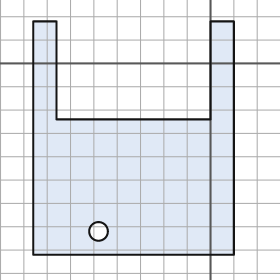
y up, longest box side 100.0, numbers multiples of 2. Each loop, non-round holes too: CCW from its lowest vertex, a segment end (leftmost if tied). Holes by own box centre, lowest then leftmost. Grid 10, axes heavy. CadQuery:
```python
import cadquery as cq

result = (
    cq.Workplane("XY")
    .moveTo(-76.0, -82.0)
    .lineTo(10.0, -82.0)
    .lineTo(10.0, 18.0)
    .lineTo(0.0, 18.0)
    .lineTo(0.0, -24.0)
    .lineTo(-66.0, -24.0)
    .lineTo(-66.0, 18.0)
    .lineTo(-76.0, 18.0)
    .close()
    .moveTo(-48.0, -72.0)
    .circle(4.0)
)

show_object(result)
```